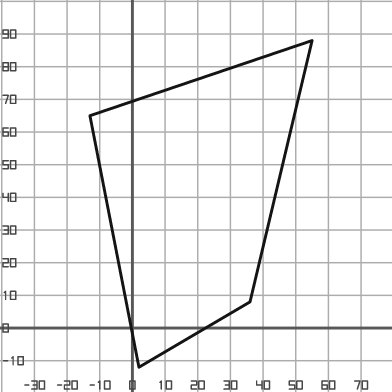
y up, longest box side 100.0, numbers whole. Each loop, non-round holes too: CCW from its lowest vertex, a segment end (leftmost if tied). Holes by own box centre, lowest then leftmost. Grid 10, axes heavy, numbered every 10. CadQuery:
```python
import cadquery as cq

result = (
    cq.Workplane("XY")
    .moveTo(2.0, -12.0)
    .lineTo(36.0, 8.0)
    .lineTo(55.0, 88.0)
    .lineTo(-13.0, 65.0)
    .close()
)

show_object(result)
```